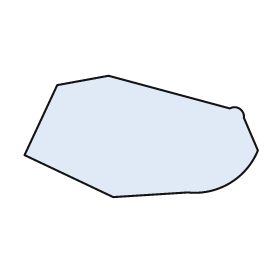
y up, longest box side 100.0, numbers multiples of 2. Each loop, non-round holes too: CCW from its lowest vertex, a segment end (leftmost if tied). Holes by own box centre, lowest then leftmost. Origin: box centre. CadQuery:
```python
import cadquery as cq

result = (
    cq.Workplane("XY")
    .moveTo(-12.0, -26.0)
    .lineTo(20.0, -24.0)
    .threePointArc((38.0, -20.0), (50.0, -6.0))
    .lineTo(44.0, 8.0)
    .threePointArc((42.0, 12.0), (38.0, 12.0))
    .lineTo(-14.0, 26.0)
    .lineTo(-36.0, 22.0)
    .lineTo(-50.0, -8.0)
    .close()
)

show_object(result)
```